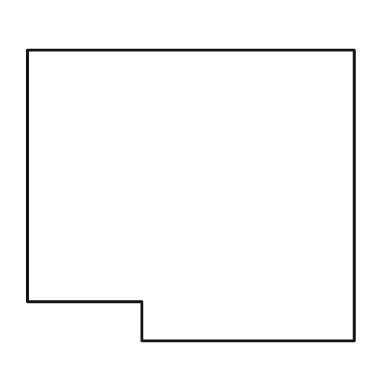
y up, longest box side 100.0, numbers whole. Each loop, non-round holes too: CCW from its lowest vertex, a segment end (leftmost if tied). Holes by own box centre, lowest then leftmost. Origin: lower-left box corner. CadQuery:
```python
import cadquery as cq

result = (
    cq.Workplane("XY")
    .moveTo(35.0, 0.0)
    .lineTo(100.0, 0.0)
    .lineTo(100.0, 89.0)
    .lineTo(0.0, 89.0)
    .lineTo(0.0, 12.0)
    .lineTo(35.0, 12.0)
    .close()
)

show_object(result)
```